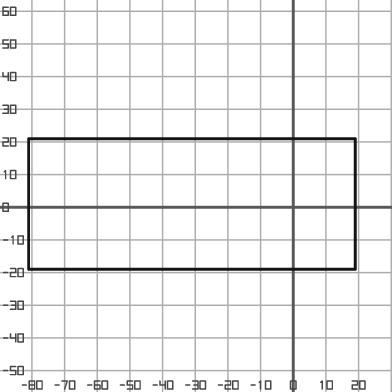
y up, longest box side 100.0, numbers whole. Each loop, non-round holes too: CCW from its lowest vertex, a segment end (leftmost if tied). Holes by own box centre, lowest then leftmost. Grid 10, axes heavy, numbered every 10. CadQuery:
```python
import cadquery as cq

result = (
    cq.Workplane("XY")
    .moveTo(-81.0, -19.0)
    .lineTo(19.0, -19.0)
    .lineTo(19.0, 21.0)
    .lineTo(-81.0, 21.0)
    .close()
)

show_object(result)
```